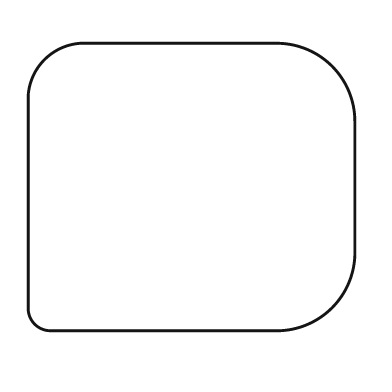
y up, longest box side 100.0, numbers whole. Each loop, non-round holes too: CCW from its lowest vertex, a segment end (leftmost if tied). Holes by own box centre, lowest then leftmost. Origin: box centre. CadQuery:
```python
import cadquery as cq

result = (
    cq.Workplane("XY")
    .moveTo(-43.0, -44.0)
    .lineTo(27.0, -44.0)
    .threePointArc((43.0, -37.0), (50.0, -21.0))
    .lineTo(50.0, 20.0)
    .threePointArc((43.0, 37.0), (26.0, 44.0))
    .lineTo(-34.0, 44.0)
    .threePointArc((-45.0, 39.0), (-50.0, 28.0))
    .lineTo(-50.0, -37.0)
    .threePointArc((-48.0, -42.0), (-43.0, -44.0))
    .close()
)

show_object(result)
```